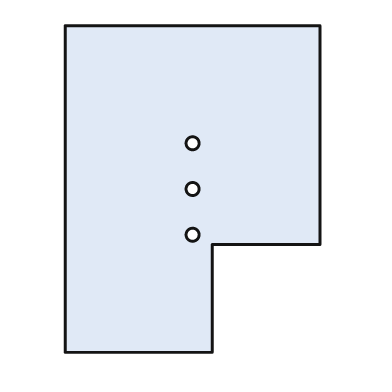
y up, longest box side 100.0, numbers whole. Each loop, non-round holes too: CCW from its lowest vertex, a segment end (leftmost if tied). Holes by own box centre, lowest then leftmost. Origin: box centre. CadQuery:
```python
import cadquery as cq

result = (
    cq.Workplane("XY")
    .moveTo(-39.0, -50.0)
    .lineTo(6.0, -50.0)
    .lineTo(6.0, -17.0)
    .lineTo(39.0, -17.0)
    .lineTo(39.0, 50.0)
    .lineTo(-39.0, 50.0)
    .close()
    .moveTo(0.0, -14.0)
    .circle(2.0)
    .moveTo(0.0, 0.0)
    .circle(2.0)
    .moveTo(0.0, 14.0)
    .circle(2.0)
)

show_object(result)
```